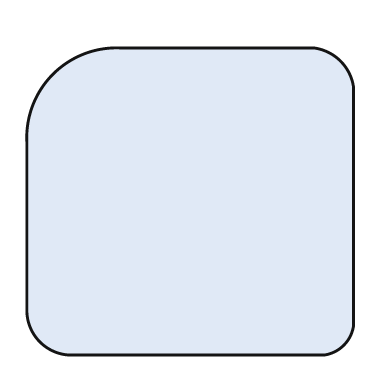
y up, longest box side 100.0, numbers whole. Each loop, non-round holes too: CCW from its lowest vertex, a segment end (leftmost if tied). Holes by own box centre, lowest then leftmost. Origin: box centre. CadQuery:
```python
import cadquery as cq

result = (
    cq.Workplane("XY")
    .moveTo(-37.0, -47.0)
    .lineTo(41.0, -47.0)
    .threePointArc((47.0, -44.0), (50.0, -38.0))
    .lineTo(50.0, 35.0)
    .threePointArc((46.0, 43.0), (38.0, 47.0))
    .lineTo(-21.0, 47.0)
    .threePointArc((-42.0, 39.0), (-50.0, 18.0))
    .lineTo(-50.0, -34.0)
    .threePointArc((-46.0, -43.0), (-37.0, -47.0))
    .close()
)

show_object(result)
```